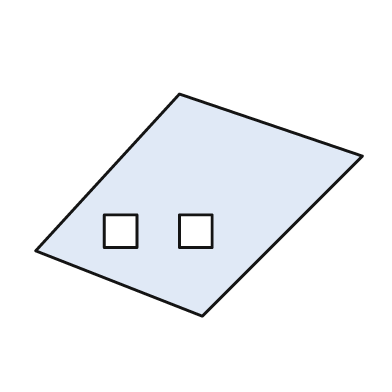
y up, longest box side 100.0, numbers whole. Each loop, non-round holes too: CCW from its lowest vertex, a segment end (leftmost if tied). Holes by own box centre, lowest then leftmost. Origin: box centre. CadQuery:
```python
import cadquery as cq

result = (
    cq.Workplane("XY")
    .moveTo(1.0, -34.0)
    .lineTo(50.0, 15.0)
    .lineTo(-6.0, 34.0)
    .lineTo(-50.0, -14.0)
    .close()
    .moveTo(-29.0, -13.0)
    .lineTo(-19.0, -13.0)
    .lineTo(-19.0, -3.0)
    .lineTo(-29.0, -3.0)
    .close()
    .moveTo(-6.0, -13.0)
    .lineTo(4.0, -13.0)
    .lineTo(4.0, -3.0)
    .lineTo(-6.0, -3.0)
    .close()
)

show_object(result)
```